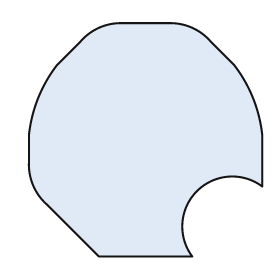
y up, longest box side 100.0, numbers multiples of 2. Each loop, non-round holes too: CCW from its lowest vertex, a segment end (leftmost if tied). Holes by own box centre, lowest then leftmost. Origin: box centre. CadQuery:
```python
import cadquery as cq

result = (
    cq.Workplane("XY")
    .moveTo(-20.0, -50.0)
    .lineTo(20.0, -50.0)
    .threePointArc((22.0, -22.0), (50.0, -20.0))
    .lineTo(50.0, 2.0)
    .threePointArc((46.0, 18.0), (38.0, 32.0))
    .lineTo(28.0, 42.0)
    .threePointArc((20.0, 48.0), (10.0, 50.0))
    .lineTo(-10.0, 50.0)
    .threePointArc((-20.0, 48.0), (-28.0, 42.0))
    .lineTo(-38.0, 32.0)
    .threePointArc((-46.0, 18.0), (-50.0, 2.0))
    .lineTo(-50.0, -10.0)
    .threePointArc((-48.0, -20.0), (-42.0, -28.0))
    .close()
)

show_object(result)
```